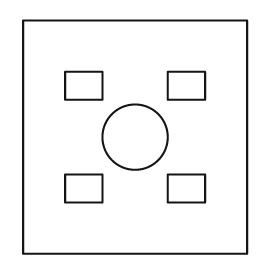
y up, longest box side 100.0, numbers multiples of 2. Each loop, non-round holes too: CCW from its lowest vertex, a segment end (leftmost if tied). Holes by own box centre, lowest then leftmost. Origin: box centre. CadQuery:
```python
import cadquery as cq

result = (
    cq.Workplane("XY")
    .moveTo(-48.0, -50.0)
    .lineTo(48.0, -50.0)
    .lineTo(48.0, 50.0)
    .lineTo(-48.0, 50.0)
    .close()
    .moveTo(-30.0, -28.0)
    .lineTo(-14.0, -28.0)
    .lineTo(-14.0, -16.0)
    .lineTo(-30.0, -16.0)
    .close()
    .moveTo(14.0, -28.0)
    .lineTo(30.0, -28.0)
    .lineTo(30.0, -16.0)
    .lineTo(14.0, -16.0)
    .close()
    .moveTo(0.0, 0.0)
    .circle(14.0)
    .moveTo(-30.0, 16.0)
    .lineTo(-14.0, 16.0)
    .lineTo(-14.0, 28.0)
    .lineTo(-30.0, 28.0)
    .close()
    .moveTo(14.0, 16.0)
    .lineTo(30.0, 16.0)
    .lineTo(30.0, 28.0)
    .lineTo(14.0, 28.0)
    .close()
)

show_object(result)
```